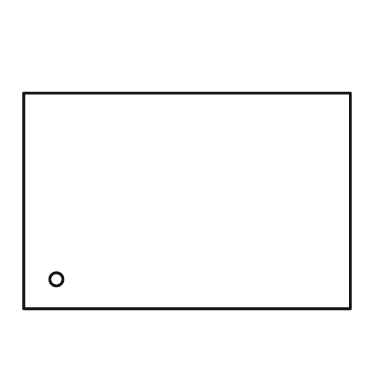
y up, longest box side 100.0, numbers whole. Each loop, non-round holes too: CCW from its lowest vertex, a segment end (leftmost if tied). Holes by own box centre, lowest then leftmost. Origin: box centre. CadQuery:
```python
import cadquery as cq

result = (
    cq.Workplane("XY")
    .moveTo(-50.0, -33.0)
    .lineTo(50.0, -33.0)
    .lineTo(50.0, 33.0)
    .lineTo(-50.0, 33.0)
    .close()
    .moveTo(-40.0, -24.0)
    .circle(2.0)
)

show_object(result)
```